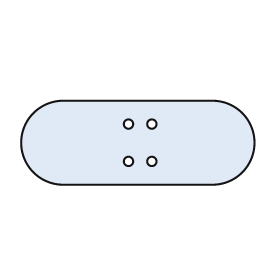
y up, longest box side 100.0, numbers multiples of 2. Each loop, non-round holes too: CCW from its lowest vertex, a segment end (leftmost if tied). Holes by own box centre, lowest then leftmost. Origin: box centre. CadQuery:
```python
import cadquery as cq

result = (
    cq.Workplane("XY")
    .moveTo(-32.0, -18.0)
    .lineTo(32.0, -18.0)
    .threePointArc((50.0, 0.0), (32.0, 18.0))
    .lineTo(-32.0, 18.0)
    .threePointArc((-50.0, 0.0), (-32.0, -18.0))
    .close()
    .moveTo(-4.0, -8.0)
    .circle(2.0)
    .moveTo(6.0, -8.0)
    .circle(2.0)
    .moveTo(-4.0, 8.0)
    .circle(2.0)
    .moveTo(6.0, 8.0)
    .circle(2.0)
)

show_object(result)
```